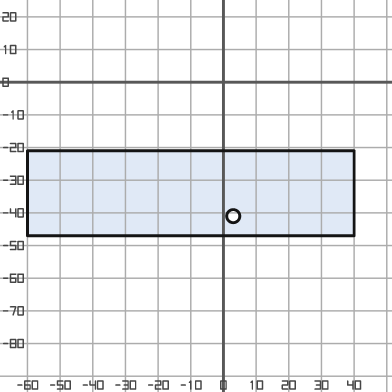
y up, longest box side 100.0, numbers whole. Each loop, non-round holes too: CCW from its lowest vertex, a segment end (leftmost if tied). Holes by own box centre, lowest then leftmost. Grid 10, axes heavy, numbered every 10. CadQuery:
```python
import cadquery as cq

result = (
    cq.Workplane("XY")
    .moveTo(-60.0, -47.0)
    .lineTo(40.0, -47.0)
    .lineTo(40.0, -21.0)
    .lineTo(-60.0, -21.0)
    .close()
    .moveTo(3.0, -41.0)
    .circle(2.0)
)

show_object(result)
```